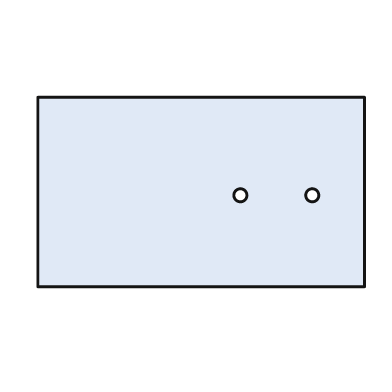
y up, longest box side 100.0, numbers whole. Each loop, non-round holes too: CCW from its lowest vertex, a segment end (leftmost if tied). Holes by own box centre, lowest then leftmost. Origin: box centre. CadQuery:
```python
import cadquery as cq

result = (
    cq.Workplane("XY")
    .moveTo(-50.0, -29.0)
    .lineTo(50.0, -29.0)
    .lineTo(50.0, 29.0)
    .lineTo(-50.0, 29.0)
    .close()
    .moveTo(12.0, -1.0)
    .circle(2.0)
    .moveTo(34.0, -1.0)
    .circle(2.0)
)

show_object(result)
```